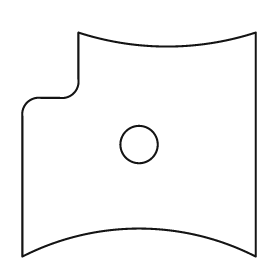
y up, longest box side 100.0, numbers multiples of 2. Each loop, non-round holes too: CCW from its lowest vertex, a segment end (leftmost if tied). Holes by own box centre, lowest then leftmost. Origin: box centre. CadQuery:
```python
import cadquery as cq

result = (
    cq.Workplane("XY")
    .moveTo(-50.0, -48.0)
    .threePointArc((0.0, -36.0), (50.0, -48.0))
    .lineTo(50.0, 48.0)
    .threePointArc((12.0, 42.0), (-26.0, 48.0))
    .lineTo(-26.0, 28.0)
    .threePointArc((-28.0, 22.0), (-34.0, 20.0))
    .lineTo(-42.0, 20.0)
    .threePointArc((-48.0, 18.0), (-50.0, 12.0))
    .close()
    .moveTo(0.0, 0.0)
    .circle(8.0)
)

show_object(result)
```